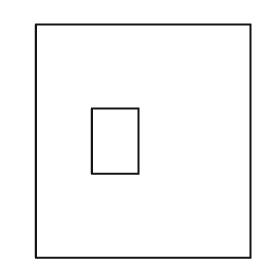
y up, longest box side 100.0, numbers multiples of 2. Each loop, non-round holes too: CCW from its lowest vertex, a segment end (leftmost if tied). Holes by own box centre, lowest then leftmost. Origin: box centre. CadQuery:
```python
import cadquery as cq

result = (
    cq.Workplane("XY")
    .moveTo(-46.0, -50.0)
    .lineTo(46.0, -50.0)
    .lineTo(46.0, 50.0)
    .lineTo(-46.0, 50.0)
    .close()
    .moveTo(-22.0, -14.0)
    .lineTo(-2.0, -14.0)
    .lineTo(-2.0, 14.0)
    .lineTo(-22.0, 14.0)
    .close()
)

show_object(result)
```